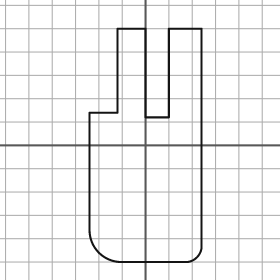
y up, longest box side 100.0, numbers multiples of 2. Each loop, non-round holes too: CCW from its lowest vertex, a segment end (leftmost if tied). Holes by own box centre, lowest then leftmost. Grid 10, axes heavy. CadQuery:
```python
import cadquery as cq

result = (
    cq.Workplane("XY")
    .moveTo(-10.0, -50.0)
    .lineTo(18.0, -50.0)
    .threePointArc((22.0, -48.0), (24.0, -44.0))
    .lineTo(24.0, 50.0)
    .lineTo(10.0, 50.0)
    .lineTo(10.0, 12.0)
    .lineTo(0.0, 12.0)
    .lineTo(0.0, 50.0)
    .lineTo(-12.0, 50.0)
    .lineTo(-12.0, 14.0)
    .lineTo(-24.0, 14.0)
    .lineTo(-24.0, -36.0)
    .threePointArc((-20.0, -46.0), (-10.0, -50.0))
    .close()
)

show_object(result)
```